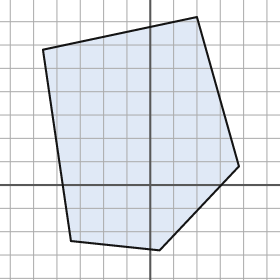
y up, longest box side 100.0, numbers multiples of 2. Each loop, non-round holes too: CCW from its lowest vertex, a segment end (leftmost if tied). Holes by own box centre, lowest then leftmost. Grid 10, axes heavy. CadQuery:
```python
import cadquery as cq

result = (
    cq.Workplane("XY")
    .moveTo(4.0, -28.0)
    .lineTo(38.0, 8.0)
    .lineTo(20.0, 72.0)
    .lineTo(-46.0, 58.0)
    .lineTo(-34.0, -24.0)
    .close()
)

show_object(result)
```